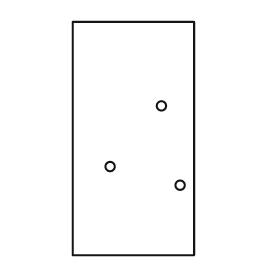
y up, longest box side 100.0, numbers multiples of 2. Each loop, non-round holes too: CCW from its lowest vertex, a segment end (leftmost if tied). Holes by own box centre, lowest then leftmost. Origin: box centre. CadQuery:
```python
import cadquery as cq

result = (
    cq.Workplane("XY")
    .moveTo(-26.0, -50.0)
    .lineTo(26.0, -50.0)
    .lineTo(26.0, 50.0)
    .lineTo(-26.0, 50.0)
    .close()
    .moveTo(20.0, -20.0)
    .circle(2.0)
    .moveTo(-10.0, -12.0)
    .circle(2.0)
    .moveTo(12.0, 14.0)
    .circle(2.0)
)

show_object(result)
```